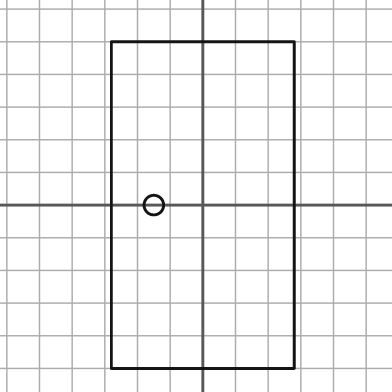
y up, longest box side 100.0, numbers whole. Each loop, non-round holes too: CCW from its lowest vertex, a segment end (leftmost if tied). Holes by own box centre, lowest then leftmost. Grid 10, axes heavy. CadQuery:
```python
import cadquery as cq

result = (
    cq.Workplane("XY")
    .moveTo(-28.0, -50.0)
    .lineTo(28.0, -50.0)
    .lineTo(28.0, 50.0)
    .lineTo(-28.0, 50.0)
    .close()
    .moveTo(-15.0, 0.0)
    .circle(3.0)
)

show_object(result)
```